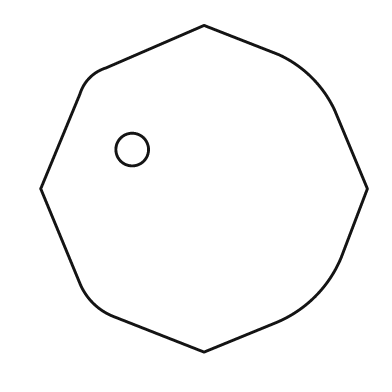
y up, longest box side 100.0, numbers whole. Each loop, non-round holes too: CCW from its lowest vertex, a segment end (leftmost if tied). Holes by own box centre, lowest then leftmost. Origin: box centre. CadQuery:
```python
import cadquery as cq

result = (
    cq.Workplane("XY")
    .moveTo(0.0, -50.0)
    .lineTo(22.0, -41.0)
    .threePointArc((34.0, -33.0), (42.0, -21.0))
    .lineTo(50.0, 0.0)
    .lineTo(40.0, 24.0)
    .threePointArc((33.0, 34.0), (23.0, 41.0))
    .lineTo(0.0, 50.0)
    .lineTo(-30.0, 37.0)
    .threePointArc((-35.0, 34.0), (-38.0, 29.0))
    .lineTo(-50.0, 0.0)
    .lineTo(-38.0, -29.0)
    .threePointArc((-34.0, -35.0), (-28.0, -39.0))
    .close()
    .moveTo(-22.0, 12.0)
    .circle(5.0)
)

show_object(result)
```